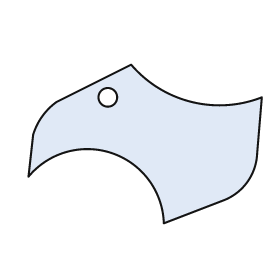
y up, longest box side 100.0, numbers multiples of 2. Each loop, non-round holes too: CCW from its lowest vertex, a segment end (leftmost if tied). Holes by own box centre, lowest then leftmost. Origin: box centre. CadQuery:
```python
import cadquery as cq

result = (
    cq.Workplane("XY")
    .moveTo(8.0, -34.0)
    .lineTo(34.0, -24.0)
    .threePointArc((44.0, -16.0), (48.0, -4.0))
    .lineTo(50.0, 20.0)
    .threePointArc((20.0, 18.0), (-6.0, 34.0))
    .lineTo(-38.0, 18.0)
    .threePointArc((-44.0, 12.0), (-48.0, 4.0))
    .lineTo(-50.0, -14.0)
    .threePointArc((-14.0, -4.0), (8.0, -34.0))
    .close()
    .moveTo(-16.0, 20.0)
    .circle(4.0)
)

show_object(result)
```